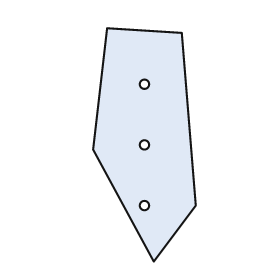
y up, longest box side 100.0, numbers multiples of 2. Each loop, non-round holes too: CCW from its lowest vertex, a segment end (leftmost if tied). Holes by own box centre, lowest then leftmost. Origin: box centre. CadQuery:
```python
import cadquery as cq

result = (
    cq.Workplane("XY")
    .moveTo(4.0, -50.0)
    .lineTo(22.0, -26.0)
    .lineTo(16.0, 48.0)
    .lineTo(-16.0, 50.0)
    .lineTo(-22.0, -2.0)
    .close()
    .moveTo(0.0, -26.0)
    .circle(2.0)
    .moveTo(0.0, 0.0)
    .circle(2.0)
    .moveTo(0.0, 26.0)
    .circle(2.0)
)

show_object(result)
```